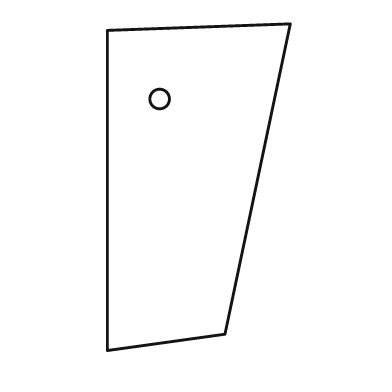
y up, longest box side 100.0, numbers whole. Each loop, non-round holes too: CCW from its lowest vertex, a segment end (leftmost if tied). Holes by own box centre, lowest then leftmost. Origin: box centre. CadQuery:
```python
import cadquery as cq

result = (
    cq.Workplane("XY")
    .moveTo(-28.0, -50.0)
    .lineTo(8.0, -45.0)
    .lineTo(28.0, 50.0)
    .lineTo(-28.0, 48.0)
    .close()
    .moveTo(-12.0, 27.0)
    .circle(3.0)
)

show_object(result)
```